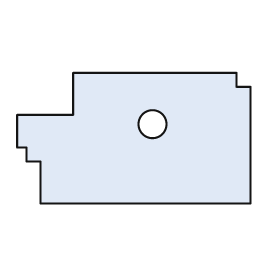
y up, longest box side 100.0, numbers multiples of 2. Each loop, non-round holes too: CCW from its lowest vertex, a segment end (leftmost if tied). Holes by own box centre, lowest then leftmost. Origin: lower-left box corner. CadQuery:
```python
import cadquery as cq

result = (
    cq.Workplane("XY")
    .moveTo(10.0, 0.0)
    .lineTo(100.0, 0.0)
    .lineTo(100.0, 50.0)
    .lineTo(94.0, 50.0)
    .lineTo(94.0, 56.0)
    .lineTo(24.0, 56.0)
    .lineTo(24.0, 38.0)
    .lineTo(0.0, 38.0)
    .lineTo(0.0, 24.0)
    .lineTo(4.0, 24.0)
    .lineTo(4.0, 18.0)
    .lineTo(10.0, 18.0)
    .close()
    .moveTo(58.0, 34.0)
    .circle(6.0)
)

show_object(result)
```